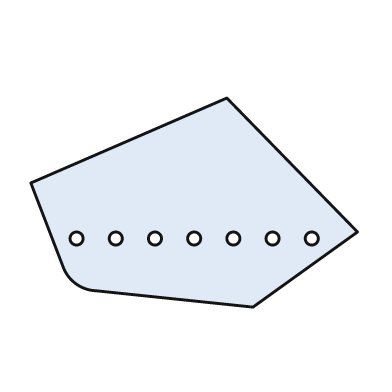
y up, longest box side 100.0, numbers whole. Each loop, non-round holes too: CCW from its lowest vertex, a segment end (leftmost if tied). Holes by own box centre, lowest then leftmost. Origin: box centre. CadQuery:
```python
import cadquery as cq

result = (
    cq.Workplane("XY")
    .moveTo(18.0, -32.0)
    .lineTo(50.0, -9.0)
    .lineTo(10.0, 32.0)
    .lineTo(-50.0, 6.0)
    .lineTo(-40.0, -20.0)
    .threePointArc((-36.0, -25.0), (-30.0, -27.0))
    .close()
    .moveTo(-36.0, -11.0)
    .circle(2.0)
    .moveTo(-24.0, -11.0)
    .circle(2.0)
    .moveTo(-12.0, -11.0)
    .circle(2.0)
    .moveTo(0.0, -11.0)
    .circle(2.0)
    .moveTo(12.0, -11.0)
    .circle(2.0)
    .moveTo(24.0, -11.0)
    .circle(2.0)
    .moveTo(36.0, -11.0)
    .circle(2.0)
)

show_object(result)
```